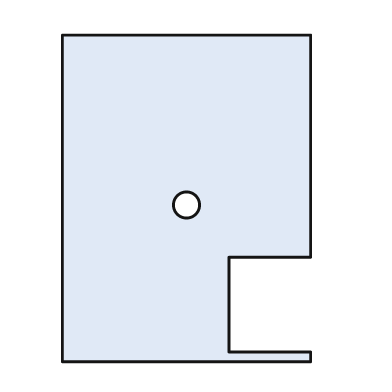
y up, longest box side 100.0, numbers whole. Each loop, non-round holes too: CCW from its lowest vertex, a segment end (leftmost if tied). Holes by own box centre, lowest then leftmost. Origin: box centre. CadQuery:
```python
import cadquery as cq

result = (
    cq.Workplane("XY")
    .moveTo(-38.0, -50.0)
    .lineTo(38.0, -50.0)
    .lineTo(38.0, -47.0)
    .lineTo(13.0, -47.0)
    .lineTo(13.0, -18.0)
    .lineTo(38.0, -18.0)
    .lineTo(38.0, 50.0)
    .lineTo(-38.0, 50.0)
    .close()
    .moveTo(0.0, -2.0)
    .circle(4.0)
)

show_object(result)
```